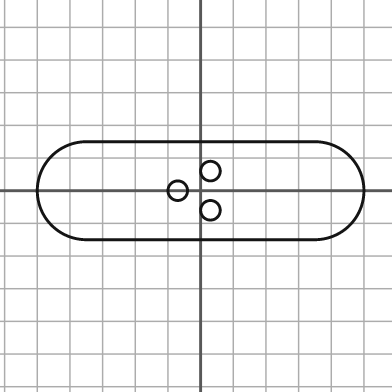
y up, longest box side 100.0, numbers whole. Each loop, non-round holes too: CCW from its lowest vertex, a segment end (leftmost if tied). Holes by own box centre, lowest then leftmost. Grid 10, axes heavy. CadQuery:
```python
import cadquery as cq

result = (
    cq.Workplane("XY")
    .moveTo(-35.0, -15.0)
    .lineTo(35.0, -15.0)
    .threePointArc((50.0, 0.0), (35.0, 15.0))
    .lineTo(-35.0, 15.0)
    .threePointArc((-50.0, 0.0), (-35.0, -15.0))
    .close()
    .moveTo(3.0, -6.0)
    .circle(3.0)
    .moveTo(-7.0, 0.0)
    .circle(3.0)
    .moveTo(3.0, 6.0)
    .circle(3.0)
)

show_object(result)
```